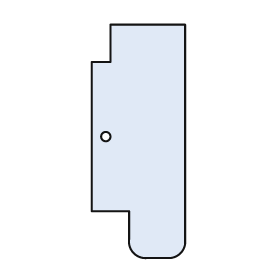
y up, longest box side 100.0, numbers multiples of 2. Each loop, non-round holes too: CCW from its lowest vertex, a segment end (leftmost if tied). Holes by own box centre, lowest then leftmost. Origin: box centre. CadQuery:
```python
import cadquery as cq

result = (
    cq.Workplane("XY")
    .moveTo(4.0, -50.0)
    .lineTo(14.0, -50.0)
    .threePointArc((18.0, -48.0), (20.0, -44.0))
    .lineTo(20.0, 50.0)
    .lineTo(-12.0, 50.0)
    .lineTo(-12.0, 34.0)
    .lineTo(-20.0, 34.0)
    .lineTo(-20.0, -30.0)
    .lineTo(-4.0, -30.0)
    .lineTo(-4.0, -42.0)
    .threePointArc((-2.0, -48.0), (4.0, -50.0))
    .close()
    .moveTo(-14.0, 2.0)
    .circle(2.0)
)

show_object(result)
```